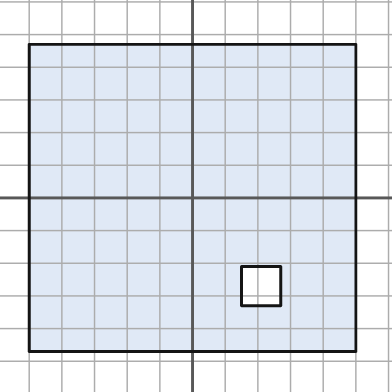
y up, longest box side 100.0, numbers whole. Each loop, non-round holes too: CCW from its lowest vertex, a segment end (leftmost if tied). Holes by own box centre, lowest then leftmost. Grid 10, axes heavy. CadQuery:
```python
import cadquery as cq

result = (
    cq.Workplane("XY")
    .moveTo(-50.0, -47.0)
    .lineTo(50.0, -47.0)
    .lineTo(50.0, 47.0)
    .lineTo(-50.0, 47.0)
    .close()
    .moveTo(15.0, -33.0)
    .lineTo(27.0, -33.0)
    .lineTo(27.0, -21.0)
    .lineTo(15.0, -21.0)
    .close()
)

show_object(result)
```